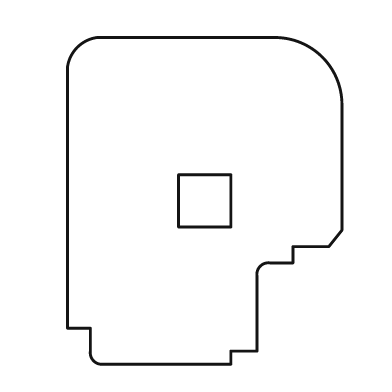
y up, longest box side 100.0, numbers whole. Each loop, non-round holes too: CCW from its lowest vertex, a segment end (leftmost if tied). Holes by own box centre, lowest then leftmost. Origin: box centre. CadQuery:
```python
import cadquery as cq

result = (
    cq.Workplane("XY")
    .moveTo(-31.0, -50.0)
    .lineTo(8.0, -50.0)
    .lineTo(8.0, -46.0)
    .lineTo(16.0, -46.0)
    .lineTo(16.0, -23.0)
    .threePointArc((17.0, -20.0), (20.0, -19.0))
    .lineTo(27.0, -19.0)
    .lineTo(27.0, -14.0)
    .lineTo(38.0, -14.0)
    .lineTo(42.0, -9.0)
    .lineTo(42.0, 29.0)
    .threePointArc((36.0, 44.0), (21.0, 50.0))
    .lineTo(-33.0, 50.0)
    .threePointArc((-39.0, 47.0), (-42.0, 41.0))
    .lineTo(-42.0, -39.0)
    .lineTo(-35.0, -39.0)
    .lineTo(-35.0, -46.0)
    .threePointArc((-34.0, -49.0), (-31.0, -50.0))
    .close()
    .moveTo(-8.0, -8.0)
    .lineTo(8.0, -8.0)
    .lineTo(8.0, 8.0)
    .lineTo(-8.0, 8.0)
    .close()
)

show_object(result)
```